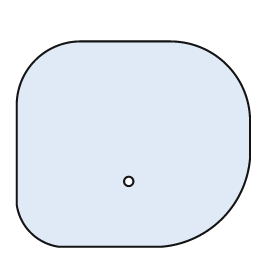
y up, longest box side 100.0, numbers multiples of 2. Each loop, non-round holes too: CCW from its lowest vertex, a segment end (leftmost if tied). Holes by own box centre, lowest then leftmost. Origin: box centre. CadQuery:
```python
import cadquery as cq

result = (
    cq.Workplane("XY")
    .moveTo(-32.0, -44.0)
    .lineTo(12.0, -44.0)
    .threePointArc((38.0, -32.0), (50.0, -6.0))
    .lineTo(50.0, 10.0)
    .threePointArc((40.0, 34.0), (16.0, 44.0))
    .lineTo(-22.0, 44.0)
    .threePointArc((-42.0, 36.0), (-50.0, 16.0))
    .lineTo(-50.0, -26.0)
    .threePointArc((-44.0, -38.0), (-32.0, -44.0))
    .close()
    .moveTo(-2.0, -16.0)
    .circle(2.0)
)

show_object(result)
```